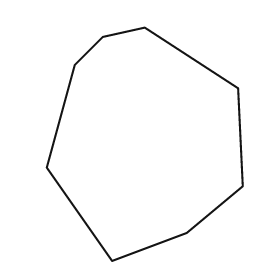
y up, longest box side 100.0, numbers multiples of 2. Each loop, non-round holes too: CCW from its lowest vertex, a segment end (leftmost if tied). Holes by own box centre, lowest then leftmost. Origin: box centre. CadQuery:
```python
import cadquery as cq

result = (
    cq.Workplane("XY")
    .moveTo(-14.0, -50.0)
    .lineTo(18.0, -38.0)
    .lineTo(42.0, -18.0)
    .lineTo(40.0, 24.0)
    .lineTo(0.0, 50.0)
    .lineTo(-18.0, 46.0)
    .lineTo(-30.0, 34.0)
    .lineTo(-42.0, -10.0)
    .close()
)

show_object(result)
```